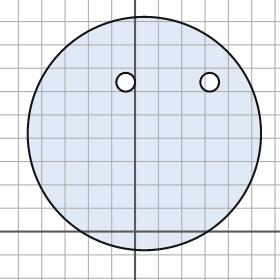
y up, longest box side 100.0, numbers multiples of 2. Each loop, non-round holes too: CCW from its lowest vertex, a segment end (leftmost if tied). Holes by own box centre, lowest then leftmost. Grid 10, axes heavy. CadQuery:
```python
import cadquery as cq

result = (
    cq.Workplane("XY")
    .moveTo(4.0, 42.0)
    .circle(50.0)
    .moveTo(-4.0, 64.0)
    .circle(4.0)
    .moveTo(32.0, 64.0)
    .circle(4.0)
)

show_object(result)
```